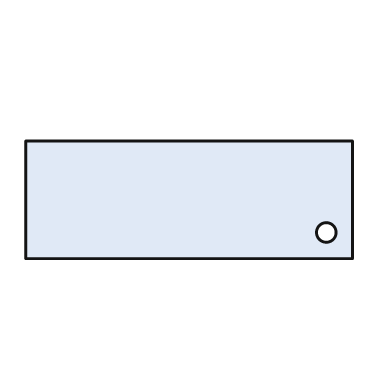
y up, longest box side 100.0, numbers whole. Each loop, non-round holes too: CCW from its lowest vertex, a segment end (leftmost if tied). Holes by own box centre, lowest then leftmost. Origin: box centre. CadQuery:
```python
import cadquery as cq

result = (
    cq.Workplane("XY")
    .moveTo(-50.0, -18.0)
    .lineTo(50.0, -18.0)
    .lineTo(50.0, 18.0)
    .lineTo(-50.0, 18.0)
    .close()
    .moveTo(42.0, -10.0)
    .circle(3.0)
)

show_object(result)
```